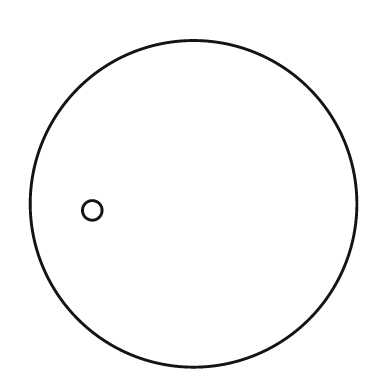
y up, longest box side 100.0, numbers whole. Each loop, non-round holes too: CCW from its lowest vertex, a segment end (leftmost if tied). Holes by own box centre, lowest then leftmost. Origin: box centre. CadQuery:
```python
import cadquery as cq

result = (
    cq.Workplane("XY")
    .moveTo(0.0, 0.0)
    .circle(50.0)
    .moveTo(-31.0, -2.0)
    .circle(3.0)
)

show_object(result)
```